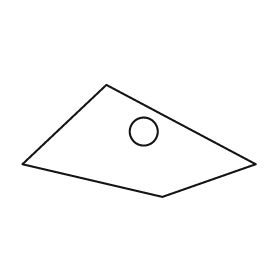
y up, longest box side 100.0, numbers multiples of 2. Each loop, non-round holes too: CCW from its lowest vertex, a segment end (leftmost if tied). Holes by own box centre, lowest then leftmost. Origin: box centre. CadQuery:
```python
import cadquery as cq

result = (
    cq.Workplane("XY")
    .moveTo(10.0, -24.0)
    .lineTo(50.0, -10.0)
    .lineTo(-14.0, 24.0)
    .lineTo(-50.0, -10.0)
    .close()
    .moveTo(2.0, 4.0)
    .circle(6.0)
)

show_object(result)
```